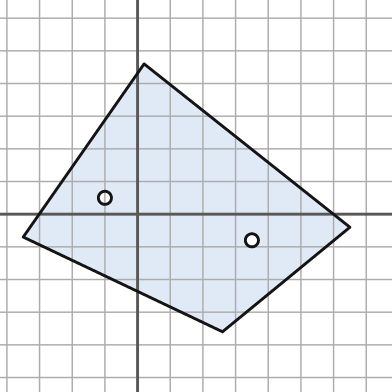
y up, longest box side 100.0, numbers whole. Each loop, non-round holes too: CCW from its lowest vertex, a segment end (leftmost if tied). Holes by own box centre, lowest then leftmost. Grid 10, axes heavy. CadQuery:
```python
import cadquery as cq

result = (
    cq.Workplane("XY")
    .moveTo(26.0, -36.0)
    .lineTo(65.0, -4.0)
    .lineTo(2.0, 46.0)
    .lineTo(-35.0, -7.0)
    .close()
    .moveTo(35.0, -8.0)
    .circle(2.0)
    .moveTo(-10.0, 5.0)
    .circle(2.0)
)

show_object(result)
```